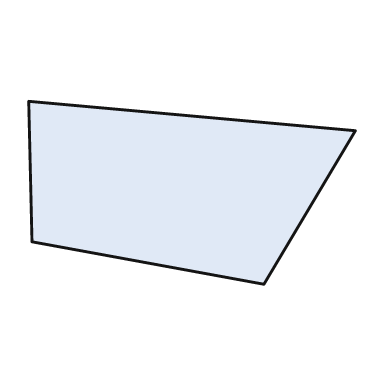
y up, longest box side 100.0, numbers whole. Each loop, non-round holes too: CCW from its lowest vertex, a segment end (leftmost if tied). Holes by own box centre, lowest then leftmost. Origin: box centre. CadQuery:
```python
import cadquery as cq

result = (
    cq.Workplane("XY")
    .moveTo(22.0, -28.0)
    .lineTo(50.0, 19.0)
    .lineTo(-50.0, 28.0)
    .lineTo(-49.0, -15.0)
    .close()
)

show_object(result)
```